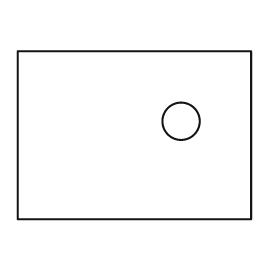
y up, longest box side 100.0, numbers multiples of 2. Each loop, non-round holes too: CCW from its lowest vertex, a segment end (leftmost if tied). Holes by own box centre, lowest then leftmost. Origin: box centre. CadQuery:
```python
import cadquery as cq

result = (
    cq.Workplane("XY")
    .moveTo(-50.0, -36.0)
    .lineTo(50.0, -36.0)
    .lineTo(50.0, 36.0)
    .lineTo(-50.0, 36.0)
    .close()
    .moveTo(20.0, 6.0)
    .circle(8.0)
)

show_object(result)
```